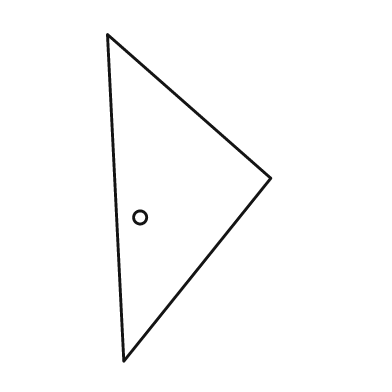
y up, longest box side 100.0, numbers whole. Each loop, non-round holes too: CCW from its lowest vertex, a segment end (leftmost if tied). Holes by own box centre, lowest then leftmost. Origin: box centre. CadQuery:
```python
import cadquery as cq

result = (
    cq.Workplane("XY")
    .moveTo(-20.0, -50.0)
    .lineTo(25.0, 6.0)
    .lineTo(-25.0, 50.0)
    .close()
    .moveTo(-15.0, -6.0)
    .circle(2.0)
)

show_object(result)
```